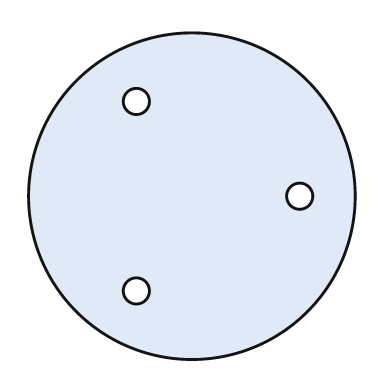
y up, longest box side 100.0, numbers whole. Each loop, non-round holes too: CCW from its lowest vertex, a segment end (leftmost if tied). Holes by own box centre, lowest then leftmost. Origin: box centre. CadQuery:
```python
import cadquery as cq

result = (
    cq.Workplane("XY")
    .moveTo(0.0, 0.0)
    .circle(50.0)
    .moveTo(-17.0, -29.0)
    .circle(4.0)
    .moveTo(33.0, 0.0)
    .circle(4.0)
    .moveTo(-17.0, 29.0)
    .circle(4.0)
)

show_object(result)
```